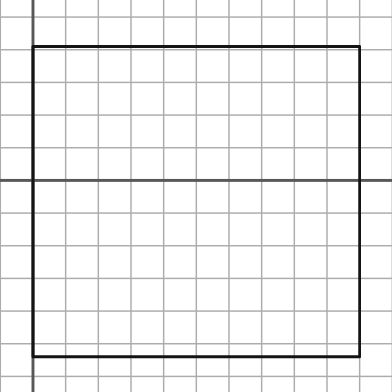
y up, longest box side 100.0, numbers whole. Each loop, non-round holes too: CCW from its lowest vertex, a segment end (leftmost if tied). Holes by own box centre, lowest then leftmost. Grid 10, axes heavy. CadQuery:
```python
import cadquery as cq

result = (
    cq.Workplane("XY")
    .moveTo(0.0, -54.0)
    .lineTo(100.0, -54.0)
    .lineTo(100.0, 41.0)
    .lineTo(0.0, 41.0)
    .close()
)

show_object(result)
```